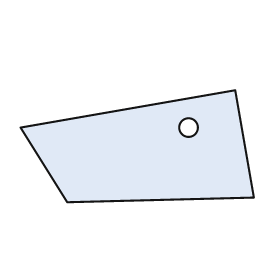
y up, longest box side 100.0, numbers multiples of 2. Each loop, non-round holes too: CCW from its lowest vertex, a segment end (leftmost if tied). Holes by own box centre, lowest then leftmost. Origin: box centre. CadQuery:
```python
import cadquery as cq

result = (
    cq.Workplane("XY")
    .moveTo(-30.0, -24.0)
    .lineTo(50.0, -22.0)
    .lineTo(42.0, 24.0)
    .lineTo(-50.0, 8.0)
    .close()
    .moveTo(22.0, 8.0)
    .circle(4.0)
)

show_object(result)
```